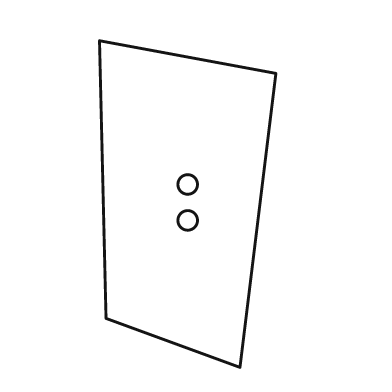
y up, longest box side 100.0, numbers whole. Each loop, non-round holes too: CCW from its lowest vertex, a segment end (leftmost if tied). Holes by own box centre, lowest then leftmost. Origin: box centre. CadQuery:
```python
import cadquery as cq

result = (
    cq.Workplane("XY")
    .moveTo(16.0, -50.0)
    .lineTo(27.0, 40.0)
    .lineTo(-27.0, 50.0)
    .lineTo(-25.0, -35.0)
    .close()
    .moveTo(0.0, -5.0)
    .circle(3.0)
    .moveTo(0.0, 6.0)
    .circle(3.0)
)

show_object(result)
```